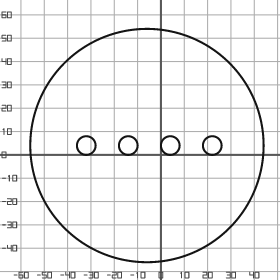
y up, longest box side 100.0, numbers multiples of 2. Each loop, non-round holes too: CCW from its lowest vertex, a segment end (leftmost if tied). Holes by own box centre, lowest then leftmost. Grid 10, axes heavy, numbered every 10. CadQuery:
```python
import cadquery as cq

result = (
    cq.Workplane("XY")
    .moveTo(-6.0, 4.0)
    .circle(50.0)
    .moveTo(-32.0, 4.0)
    .circle(4.0)
    .moveTo(-14.0, 4.0)
    .circle(4.0)
    .moveTo(4.0, 4.0)
    .circle(4.0)
    .moveTo(22.0, 4.0)
    .circle(4.0)
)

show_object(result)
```